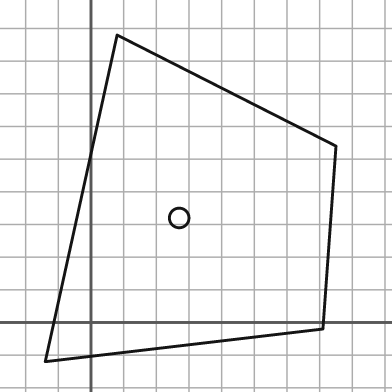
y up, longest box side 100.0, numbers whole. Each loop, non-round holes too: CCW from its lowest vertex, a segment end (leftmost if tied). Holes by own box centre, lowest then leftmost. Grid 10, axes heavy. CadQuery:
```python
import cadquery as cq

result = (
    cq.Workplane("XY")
    .moveTo(-14.0, -12.0)
    .lineTo(71.0, -2.0)
    .lineTo(75.0, 54.0)
    .lineTo(8.0, 88.0)
    .close()
    .moveTo(27.0, 32.0)
    .circle(3.0)
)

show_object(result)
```